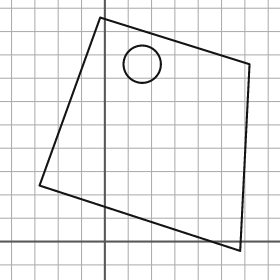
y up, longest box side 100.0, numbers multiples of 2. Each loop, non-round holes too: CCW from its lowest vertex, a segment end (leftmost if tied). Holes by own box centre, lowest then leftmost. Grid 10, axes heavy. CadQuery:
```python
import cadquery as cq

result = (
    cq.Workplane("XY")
    .moveTo(58.0, -4.0)
    .lineTo(62.0, 76.0)
    .lineTo(-2.0, 96.0)
    .lineTo(-28.0, 24.0)
    .close()
    .moveTo(16.0, 76.0)
    .circle(8.0)
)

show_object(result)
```